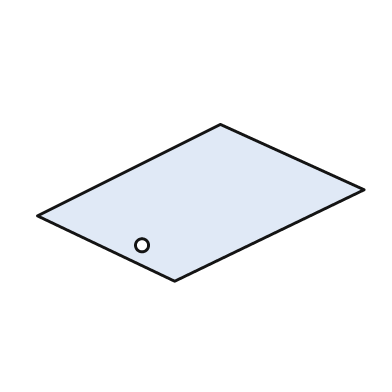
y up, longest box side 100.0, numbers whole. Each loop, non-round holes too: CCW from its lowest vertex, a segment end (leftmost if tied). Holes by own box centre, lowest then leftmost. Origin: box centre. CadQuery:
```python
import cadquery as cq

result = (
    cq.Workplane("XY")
    .moveTo(-8.0, -24.0)
    .lineTo(50.0, 4.0)
    .lineTo(6.0, 24.0)
    .lineTo(-50.0, -4.0)
    .close()
    .moveTo(-18.0, -13.0)
    .circle(2.0)
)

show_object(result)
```